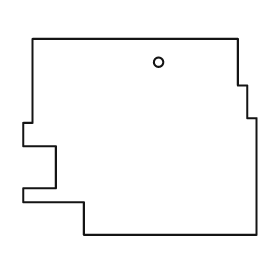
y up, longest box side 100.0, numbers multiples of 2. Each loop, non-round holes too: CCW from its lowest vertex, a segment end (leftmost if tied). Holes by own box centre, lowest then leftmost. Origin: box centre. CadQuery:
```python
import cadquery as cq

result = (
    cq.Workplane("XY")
    .moveTo(-24.0, -42.0)
    .lineTo(50.0, -42.0)
    .lineTo(50.0, 8.0)
    .lineTo(46.0, 8.0)
    .lineTo(46.0, 22.0)
    .lineTo(42.0, 22.0)
    .lineTo(42.0, 42.0)
    .lineTo(-46.0, 42.0)
    .lineTo(-46.0, 6.0)
    .lineTo(-50.0, 6.0)
    .lineTo(-50.0, -4.0)
    .lineTo(-36.0, -4.0)
    .lineTo(-36.0, -22.0)
    .lineTo(-50.0, -22.0)
    .lineTo(-50.0, -28.0)
    .lineTo(-24.0, -28.0)
    .close()
    .moveTo(8.0, 32.0)
    .circle(2.0)
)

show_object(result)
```